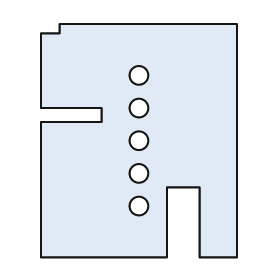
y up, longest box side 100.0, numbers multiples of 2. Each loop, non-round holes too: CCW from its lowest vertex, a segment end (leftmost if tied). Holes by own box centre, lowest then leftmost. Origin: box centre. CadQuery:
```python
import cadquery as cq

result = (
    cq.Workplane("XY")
    .moveTo(-42.0, -50.0)
    .lineTo(12.0, -50.0)
    .lineTo(12.0, -20.0)
    .lineTo(26.0, -20.0)
    .lineTo(26.0, -50.0)
    .lineTo(42.0, -50.0)
    .lineTo(42.0, 50.0)
    .lineTo(-34.0, 50.0)
    .lineTo(-34.0, 46.0)
    .lineTo(-42.0, 46.0)
    .lineTo(-42.0, 14.0)
    .lineTo(-16.0, 14.0)
    .lineTo(-16.0, 8.0)
    .lineTo(-42.0, 8.0)
    .close()
    .moveTo(0.0, -28.0)
    .circle(4.0)
    .moveTo(0.0, -14.0)
    .circle(4.0)
    .moveTo(0.0, 0.0)
    .circle(4.0)
    .moveTo(0.0, 14.0)
    .circle(4.0)
    .moveTo(0.0, 28.0)
    .circle(4.0)
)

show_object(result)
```